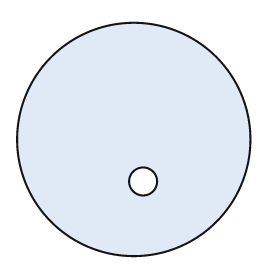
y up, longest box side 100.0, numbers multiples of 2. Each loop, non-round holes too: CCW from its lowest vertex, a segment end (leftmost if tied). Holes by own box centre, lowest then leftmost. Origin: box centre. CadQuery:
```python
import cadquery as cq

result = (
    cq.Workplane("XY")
    .moveTo(0.0, 0.0)
    .circle(50.0)
    .moveTo(4.0, -18.0)
    .circle(6.0)
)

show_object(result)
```